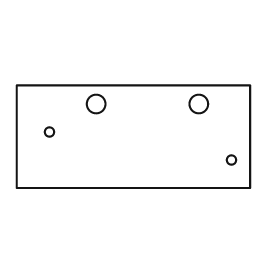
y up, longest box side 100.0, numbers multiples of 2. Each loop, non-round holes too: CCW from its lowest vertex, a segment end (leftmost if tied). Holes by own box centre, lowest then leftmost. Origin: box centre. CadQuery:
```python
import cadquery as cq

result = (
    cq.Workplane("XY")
    .moveTo(-50.0, -22.0)
    .lineTo(50.0, -22.0)
    .lineTo(50.0, 22.0)
    .lineTo(-50.0, 22.0)
    .close()
    .moveTo(42.0, -10.0)
    .circle(2.0)
    .moveTo(-36.0, 2.0)
    .circle(2.0)
    .moveTo(-16.0, 14.0)
    .circle(4.0)
    .moveTo(28.0, 14.0)
    .circle(4.0)
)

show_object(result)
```